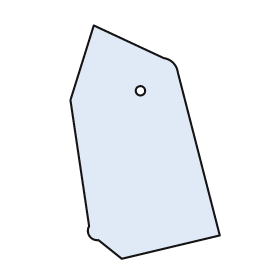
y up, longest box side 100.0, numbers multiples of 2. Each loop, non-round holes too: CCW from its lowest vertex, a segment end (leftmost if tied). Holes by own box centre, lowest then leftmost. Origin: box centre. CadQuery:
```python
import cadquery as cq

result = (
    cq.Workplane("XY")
    .moveTo(-10.0, -50.0)
    .lineTo(32.0, -40.0)
    .lineTo(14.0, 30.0)
    .threePointArc((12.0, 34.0), (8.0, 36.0))
    .lineTo(-22.0, 50.0)
    .lineTo(-32.0, 18.0)
    .lineTo(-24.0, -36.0)
    .threePointArc((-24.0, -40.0), (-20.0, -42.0))
    .close()
    .moveTo(-2.0, 22.0)
    .circle(2.0)
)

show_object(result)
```